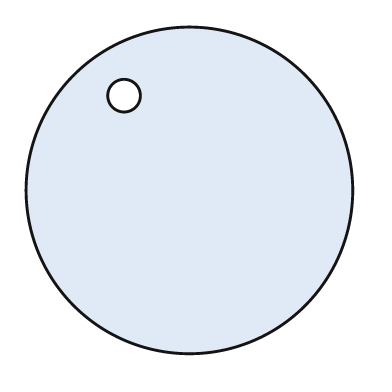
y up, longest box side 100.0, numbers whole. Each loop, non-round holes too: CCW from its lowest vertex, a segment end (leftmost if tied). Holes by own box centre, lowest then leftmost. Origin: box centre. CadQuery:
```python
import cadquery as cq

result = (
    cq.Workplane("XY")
    .moveTo(0.0, 0.0)
    .circle(50.0)
    .moveTo(-20.0, 29.0)
    .circle(5.0)
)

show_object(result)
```